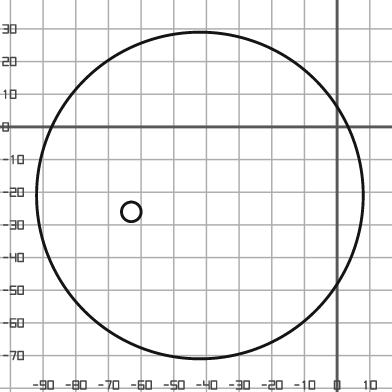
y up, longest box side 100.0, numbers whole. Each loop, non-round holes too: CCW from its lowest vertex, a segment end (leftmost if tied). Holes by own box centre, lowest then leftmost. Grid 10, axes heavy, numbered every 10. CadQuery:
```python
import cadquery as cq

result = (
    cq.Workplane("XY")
    .moveTo(-42.0, -21.0)
    .circle(50.0)
    .moveTo(-63.0, -26.0)
    .circle(3.0)
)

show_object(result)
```